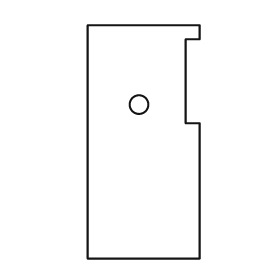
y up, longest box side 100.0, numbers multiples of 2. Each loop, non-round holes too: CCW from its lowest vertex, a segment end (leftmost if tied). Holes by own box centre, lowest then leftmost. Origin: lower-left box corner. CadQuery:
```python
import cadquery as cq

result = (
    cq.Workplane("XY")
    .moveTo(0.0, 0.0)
    .lineTo(48.0, 0.0)
    .lineTo(48.0, 58.0)
    .lineTo(42.0, 58.0)
    .lineTo(42.0, 94.0)
    .lineTo(48.0, 94.0)
    .lineTo(48.0, 100.0)
    .lineTo(0.0, 100.0)
    .close()
    .moveTo(22.0, 66.0)
    .circle(4.0)
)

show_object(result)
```